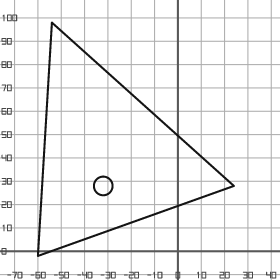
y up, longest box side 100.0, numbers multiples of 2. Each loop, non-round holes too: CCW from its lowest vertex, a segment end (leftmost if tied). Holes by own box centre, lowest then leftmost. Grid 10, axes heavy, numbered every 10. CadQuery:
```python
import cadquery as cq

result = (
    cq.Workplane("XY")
    .moveTo(-60.0, -2.0)
    .lineTo(24.0, 28.0)
    .lineTo(-54.0, 98.0)
    .close()
    .moveTo(-32.0, 28.0)
    .circle(4.0)
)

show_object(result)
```